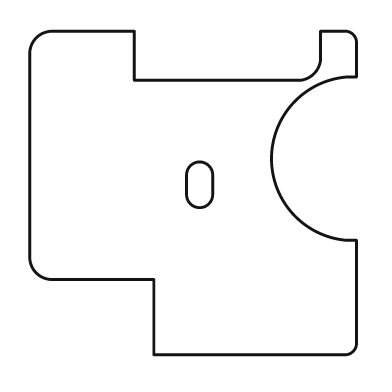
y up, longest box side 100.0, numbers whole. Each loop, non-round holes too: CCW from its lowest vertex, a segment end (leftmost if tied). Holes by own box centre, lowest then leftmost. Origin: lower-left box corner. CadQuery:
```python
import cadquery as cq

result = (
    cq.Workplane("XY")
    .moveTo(38.0, 0.0)
    .lineTo(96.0, 0.0)
    .threePointArc((99.0, 1.0), (100.0, 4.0))
    .lineTo(100.0, 35.0)
    .lineTo(97.0, 35.0)
    .threePointArc((74.0, 60.0), (97.0, 85.0))
    .lineTo(100.0, 85.0)
    .lineTo(100.0, 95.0)
    .threePointArc((99.0, 98.0), (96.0, 99.0))
    .lineTo(89.0, 99.0)
    .lineTo(89.0, 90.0)
    .threePointArc((87.0, 86.0), (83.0, 84.0))
    .lineTo(32.0, 84.0)
    .lineTo(32.0, 99.0)
    .lineTo(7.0, 99.0)
    .threePointArc((2.0, 97.0), (0.0, 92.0))
    .lineTo(0.0, 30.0)
    .threePointArc((2.0, 25.0), (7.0, 23.0))
    .lineTo(38.0, 23.0)
    .close()
    .moveTo(48.0, 49.0)
    .threePointArc((52.0, 45.0), (56.0, 49.0))
    .lineTo(56.0, 55.0)
    .threePointArc((52.0, 59.0), (48.0, 55.0))
    .close()
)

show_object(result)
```